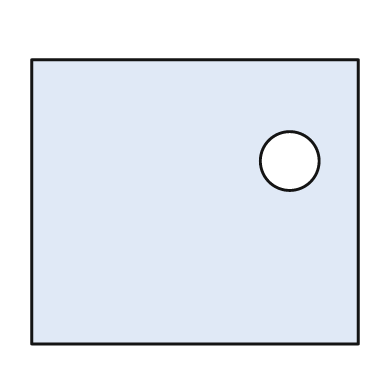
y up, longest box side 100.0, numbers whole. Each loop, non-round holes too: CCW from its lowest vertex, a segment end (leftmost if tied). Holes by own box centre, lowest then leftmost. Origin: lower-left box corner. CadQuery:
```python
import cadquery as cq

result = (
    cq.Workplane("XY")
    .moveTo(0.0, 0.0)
    .lineTo(100.0, 0.0)
    .lineTo(100.0, 87.0)
    .lineTo(0.0, 87.0)
    .close()
    .moveTo(79.0, 56.0)
    .circle(9.0)
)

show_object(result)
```